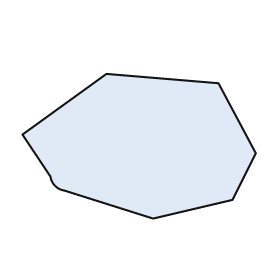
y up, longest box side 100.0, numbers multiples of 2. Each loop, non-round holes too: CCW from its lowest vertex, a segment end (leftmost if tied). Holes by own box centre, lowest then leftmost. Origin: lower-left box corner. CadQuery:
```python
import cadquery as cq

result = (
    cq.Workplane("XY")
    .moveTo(56.0, 0.0)
    .lineTo(90.0, 8.0)
    .lineTo(100.0, 28.0)
    .lineTo(84.0, 58.0)
    .lineTo(36.0, 62.0)
    .lineTo(0.0, 36.0)
    .lineTo(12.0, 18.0)
    .threePointArc((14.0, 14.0), (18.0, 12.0))
    .close()
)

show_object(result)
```